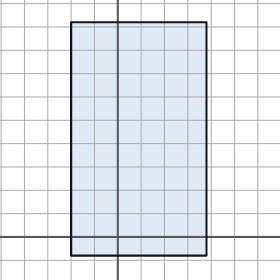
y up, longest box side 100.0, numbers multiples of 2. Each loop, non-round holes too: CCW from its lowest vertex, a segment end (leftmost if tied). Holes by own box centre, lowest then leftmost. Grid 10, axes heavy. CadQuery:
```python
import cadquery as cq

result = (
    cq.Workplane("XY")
    .moveTo(-20.0, -8.0)
    .lineTo(38.0, -8.0)
    .lineTo(38.0, 92.0)
    .lineTo(-20.0, 92.0)
    .close()
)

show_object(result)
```